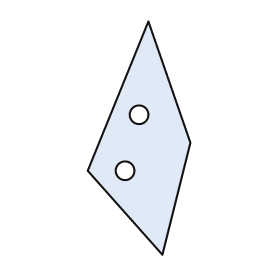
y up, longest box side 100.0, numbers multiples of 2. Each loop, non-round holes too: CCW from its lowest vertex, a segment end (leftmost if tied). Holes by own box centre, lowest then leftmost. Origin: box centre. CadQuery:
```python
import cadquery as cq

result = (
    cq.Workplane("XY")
    .moveTo(10.0, -50.0)
    .lineTo(22.0, -2.0)
    .lineTo(4.0, 50.0)
    .lineTo(-22.0, -14.0)
    .close()
    .moveTo(-6.0, -14.0)
    .circle(4.0)
    .moveTo(0.0, 10.0)
    .circle(4.0)
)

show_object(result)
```